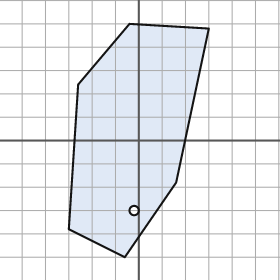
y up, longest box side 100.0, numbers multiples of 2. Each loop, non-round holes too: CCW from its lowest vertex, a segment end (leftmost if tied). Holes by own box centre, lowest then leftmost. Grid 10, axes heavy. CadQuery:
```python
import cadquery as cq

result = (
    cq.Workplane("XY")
    .moveTo(-6.0, -50.0)
    .lineTo(16.0, -18.0)
    .lineTo(30.0, 48.0)
    .lineTo(-4.0, 50.0)
    .lineTo(-26.0, 24.0)
    .lineTo(-30.0, -38.0)
    .close()
    .moveTo(-2.0, -30.0)
    .circle(2.0)
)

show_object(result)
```